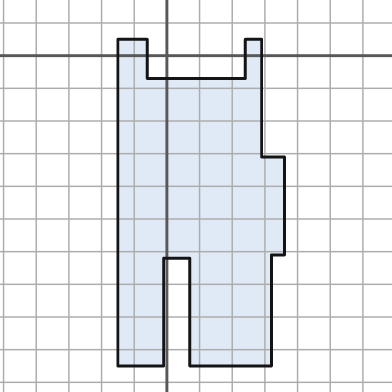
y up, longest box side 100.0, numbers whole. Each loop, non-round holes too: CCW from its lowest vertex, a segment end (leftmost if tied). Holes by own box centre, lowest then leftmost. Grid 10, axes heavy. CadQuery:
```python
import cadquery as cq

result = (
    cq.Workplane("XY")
    .moveTo(-15.0, -95.0)
    .lineTo(-1.0, -95.0)
    .lineTo(-1.0, -62.0)
    .lineTo(7.0, -62.0)
    .lineTo(7.0, -95.0)
    .lineTo(32.0, -95.0)
    .lineTo(32.0, -61.0)
    .lineTo(36.0, -61.0)
    .lineTo(36.0, -31.0)
    .lineTo(29.0, -31.0)
    .lineTo(29.0, 5.0)
    .lineTo(24.0, 5.0)
    .lineTo(24.0, -7.0)
    .lineTo(-6.0, -7.0)
    .lineTo(-6.0, 5.0)
    .lineTo(-15.0, 5.0)
    .close()
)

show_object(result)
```